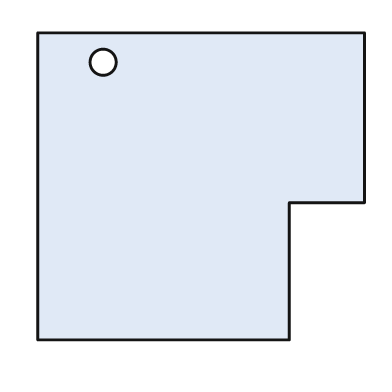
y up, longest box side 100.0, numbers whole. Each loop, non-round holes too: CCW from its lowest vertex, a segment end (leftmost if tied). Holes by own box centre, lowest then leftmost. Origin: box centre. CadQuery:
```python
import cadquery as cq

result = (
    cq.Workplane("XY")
    .moveTo(-50.0, -47.0)
    .lineTo(27.0, -47.0)
    .lineTo(27.0, -5.0)
    .lineTo(50.0, -5.0)
    .lineTo(50.0, 47.0)
    .lineTo(-50.0, 47.0)
    .close()
    .moveTo(-30.0, 38.0)
    .circle(4.0)
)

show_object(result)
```